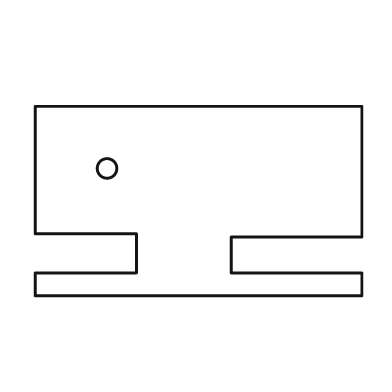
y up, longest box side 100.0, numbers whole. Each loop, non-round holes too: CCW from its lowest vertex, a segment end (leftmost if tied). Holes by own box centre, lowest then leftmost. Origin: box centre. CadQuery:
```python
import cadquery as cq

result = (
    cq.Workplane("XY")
    .moveTo(-50.0, -29.0)
    .lineTo(50.0, -29.0)
    .lineTo(50.0, -22.0)
    .lineTo(10.0, -22.0)
    .lineTo(10.0, -11.0)
    .lineTo(50.0, -11.0)
    .lineTo(50.0, 29.0)
    .lineTo(-50.0, 29.0)
    .lineTo(-50.0, -10.0)
    .lineTo(-19.0, -10.0)
    .lineTo(-19.0, -22.0)
    .lineTo(-50.0, -22.0)
    .close()
    .moveTo(-28.0, 10.0)
    .circle(3.0)
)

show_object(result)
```